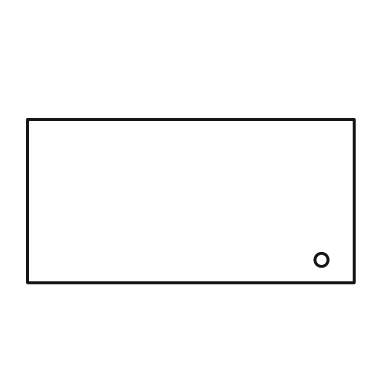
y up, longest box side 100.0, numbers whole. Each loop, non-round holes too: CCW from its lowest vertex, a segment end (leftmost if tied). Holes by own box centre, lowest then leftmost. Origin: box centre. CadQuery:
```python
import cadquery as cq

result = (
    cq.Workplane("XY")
    .moveTo(-50.0, -25.0)
    .lineTo(50.0, -25.0)
    .lineTo(50.0, 25.0)
    .lineTo(-50.0, 25.0)
    .close()
    .moveTo(40.0, -18.0)
    .circle(2.0)
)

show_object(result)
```